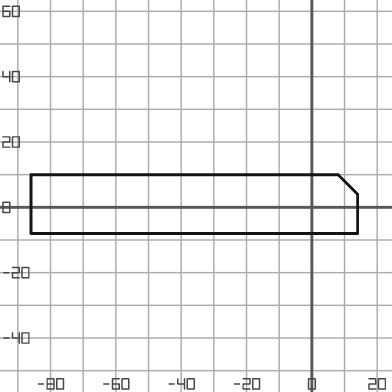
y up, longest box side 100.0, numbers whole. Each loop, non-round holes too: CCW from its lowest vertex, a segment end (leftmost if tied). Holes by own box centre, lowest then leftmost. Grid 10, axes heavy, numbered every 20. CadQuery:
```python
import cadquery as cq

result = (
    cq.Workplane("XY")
    .moveTo(-86.0, -8.0)
    .lineTo(14.0, -8.0)
    .lineTo(14.0, 4.0)
    .lineTo(8.0, 10.0)
    .lineTo(-86.0, 10.0)
    .close()
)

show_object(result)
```